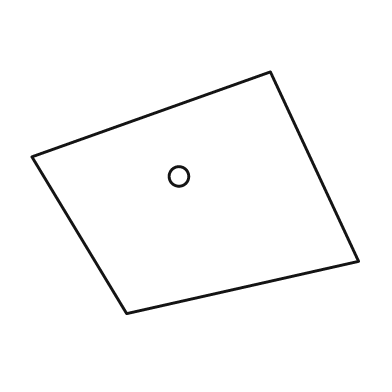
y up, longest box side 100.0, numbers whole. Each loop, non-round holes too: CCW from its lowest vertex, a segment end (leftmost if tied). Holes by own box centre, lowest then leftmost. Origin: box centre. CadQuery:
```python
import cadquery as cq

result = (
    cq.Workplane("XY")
    .moveTo(-21.0, -37.0)
    .lineTo(50.0, -21.0)
    .lineTo(23.0, 37.0)
    .lineTo(-50.0, 11.0)
    .close()
    .moveTo(-5.0, 5.0)
    .circle(3.0)
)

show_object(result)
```